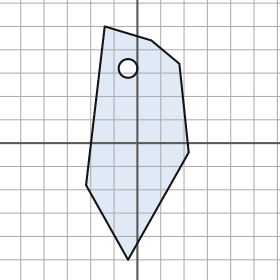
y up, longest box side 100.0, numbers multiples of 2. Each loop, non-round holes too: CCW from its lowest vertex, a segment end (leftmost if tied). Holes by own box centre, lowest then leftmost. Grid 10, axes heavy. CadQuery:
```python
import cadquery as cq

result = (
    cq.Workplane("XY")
    .moveTo(-4.0, -50.0)
    .lineTo(22.0, -4.0)
    .lineTo(18.0, 34.0)
    .lineTo(6.0, 44.0)
    .lineTo(-14.0, 50.0)
    .lineTo(-22.0, -18.0)
    .close()
    .moveTo(-4.0, 32.0)
    .circle(4.0)
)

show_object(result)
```